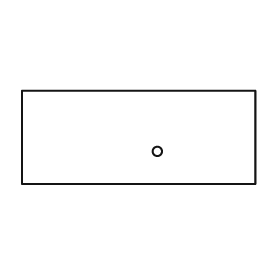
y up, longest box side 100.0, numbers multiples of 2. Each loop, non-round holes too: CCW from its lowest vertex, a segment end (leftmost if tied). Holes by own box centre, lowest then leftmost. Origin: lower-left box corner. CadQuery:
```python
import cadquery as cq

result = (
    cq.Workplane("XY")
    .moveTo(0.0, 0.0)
    .lineTo(100.0, 0.0)
    .lineTo(100.0, 40.0)
    .lineTo(0.0, 40.0)
    .close()
    .moveTo(58.0, 14.0)
    .circle(2.0)
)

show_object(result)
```